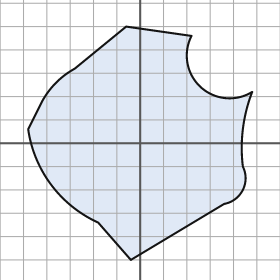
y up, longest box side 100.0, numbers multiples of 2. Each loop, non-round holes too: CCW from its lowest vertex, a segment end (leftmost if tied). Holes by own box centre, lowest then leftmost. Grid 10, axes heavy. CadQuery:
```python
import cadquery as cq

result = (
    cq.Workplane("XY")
    .moveTo(-4.0, -50.0)
    .lineTo(36.0, -26.0)
    .threePointArc((44.0, -20.0), (44.0, -10.0))
    .threePointArc((44.0, 6.0), (48.0, 22.0))
    .threePointArc((26.0, 24.0), (22.0, 46.0))
    .lineTo(-6.0, 50.0)
    .lineTo(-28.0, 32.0)
    .threePointArc((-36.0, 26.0), (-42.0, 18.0))
    .lineTo(-48.0, 6.0)
    .threePointArc((-38.0, -18.0), (-18.0, -34.0))
    .close()
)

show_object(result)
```